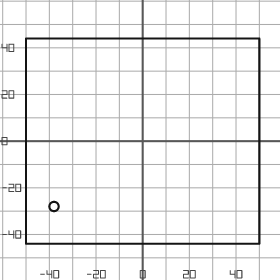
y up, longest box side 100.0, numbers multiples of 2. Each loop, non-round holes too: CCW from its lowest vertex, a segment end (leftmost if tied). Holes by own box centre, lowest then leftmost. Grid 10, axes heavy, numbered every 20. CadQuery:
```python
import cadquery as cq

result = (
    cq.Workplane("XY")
    .moveTo(-50.0, -44.0)
    .lineTo(50.0, -44.0)
    .lineTo(50.0, 44.0)
    .lineTo(-50.0, 44.0)
    .close()
    .moveTo(-38.0, -28.0)
    .circle(2.0)
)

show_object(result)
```